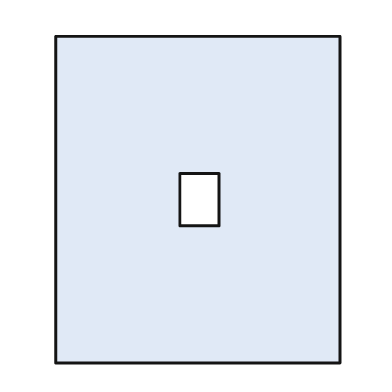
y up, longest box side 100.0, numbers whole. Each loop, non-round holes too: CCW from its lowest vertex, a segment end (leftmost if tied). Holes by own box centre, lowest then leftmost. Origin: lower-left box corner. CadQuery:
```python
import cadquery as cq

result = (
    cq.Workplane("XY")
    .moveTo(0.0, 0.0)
    .lineTo(87.0, 0.0)
    .lineTo(87.0, 100.0)
    .lineTo(0.0, 100.0)
    .close()
    .moveTo(38.0, 42.0)
    .lineTo(50.0, 42.0)
    .lineTo(50.0, 58.0)
    .lineTo(38.0, 58.0)
    .close()
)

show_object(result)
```